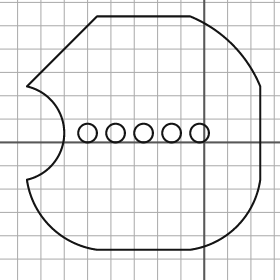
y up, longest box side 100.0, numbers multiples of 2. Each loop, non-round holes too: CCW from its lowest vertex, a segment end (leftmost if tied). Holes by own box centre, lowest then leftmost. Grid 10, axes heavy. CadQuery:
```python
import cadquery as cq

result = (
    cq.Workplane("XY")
    .moveTo(-46.0, -46.0)
    .lineTo(-6.0, -46.0)
    .threePointArc((14.0, -36.0), (24.0, -16.0))
    .lineTo(24.0, 24.0)
    .threePointArc((12.0, 42.0), (-6.0, 54.0))
    .lineTo(-46.0, 54.0)
    .lineTo(-76.0, 24.0)
    .threePointArc((-60.0, 4.0), (-76.0, -16.0))
    .threePointArc((-66.0, -36.0), (-46.0, -46.0))
    .close()
    .moveTo(-50.0, 4.0)
    .circle(4.0)
    .moveTo(-38.0, 4.0)
    .circle(4.0)
    .moveTo(-26.0, 4.0)
    .circle(4.0)
    .moveTo(-14.0, 4.0)
    .circle(4.0)
    .moveTo(-2.0, 4.0)
    .circle(4.0)
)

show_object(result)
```